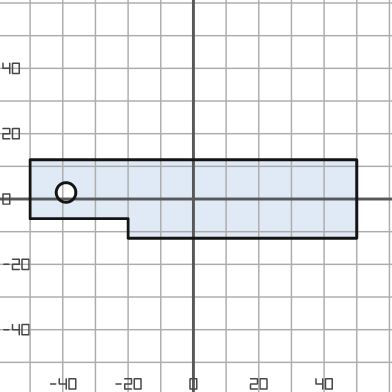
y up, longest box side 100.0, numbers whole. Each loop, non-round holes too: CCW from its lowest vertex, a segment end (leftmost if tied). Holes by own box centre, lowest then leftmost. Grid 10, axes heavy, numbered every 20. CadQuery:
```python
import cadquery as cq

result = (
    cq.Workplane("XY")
    .moveTo(-20.0, -12.0)
    .lineTo(50.0, -12.0)
    .lineTo(50.0, 12.0)
    .lineTo(-50.0, 12.0)
    .lineTo(-50.0, -6.0)
    .lineTo(-20.0, -6.0)
    .close()
    .moveTo(-39.0, 2.0)
    .circle(3.0)
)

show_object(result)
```